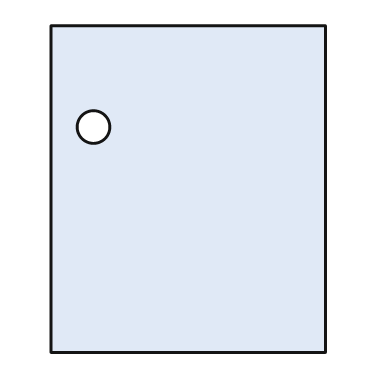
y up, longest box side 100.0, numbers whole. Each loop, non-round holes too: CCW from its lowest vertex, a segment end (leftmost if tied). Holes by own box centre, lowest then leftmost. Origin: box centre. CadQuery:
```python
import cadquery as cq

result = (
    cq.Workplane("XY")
    .moveTo(-42.0, -50.0)
    .lineTo(42.0, -50.0)
    .lineTo(42.0, 50.0)
    .lineTo(-42.0, 50.0)
    .close()
    .moveTo(-29.0, 19.0)
    .circle(5.0)
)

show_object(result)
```